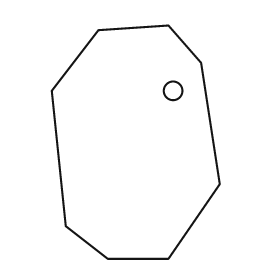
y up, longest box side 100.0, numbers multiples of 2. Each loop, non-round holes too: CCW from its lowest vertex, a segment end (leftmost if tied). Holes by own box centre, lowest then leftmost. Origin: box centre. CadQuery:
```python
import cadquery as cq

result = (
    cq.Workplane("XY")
    .moveTo(-12.0, -50.0)
    .lineTo(14.0, -50.0)
    .lineTo(36.0, -18.0)
    .lineTo(28.0, 34.0)
    .lineTo(14.0, 50.0)
    .lineTo(-16.0, 48.0)
    .lineTo(-36.0, 22.0)
    .lineTo(-30.0, -36.0)
    .close()
    .moveTo(16.0, 22.0)
    .circle(4.0)
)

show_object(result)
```